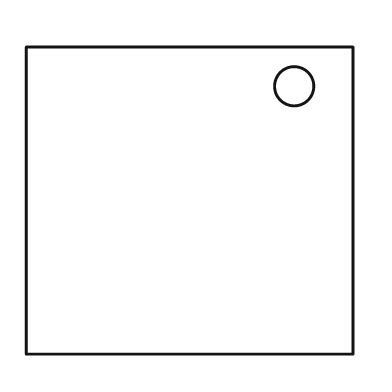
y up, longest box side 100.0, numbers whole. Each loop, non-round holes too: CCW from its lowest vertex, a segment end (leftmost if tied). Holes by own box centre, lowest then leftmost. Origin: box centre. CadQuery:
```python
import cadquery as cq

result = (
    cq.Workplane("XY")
    .moveTo(-50.0, -47.0)
    .lineTo(50.0, -47.0)
    .lineTo(50.0, 47.0)
    .lineTo(-50.0, 47.0)
    .close()
    .moveTo(32.0, 35.0)
    .circle(6.0)
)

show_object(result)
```